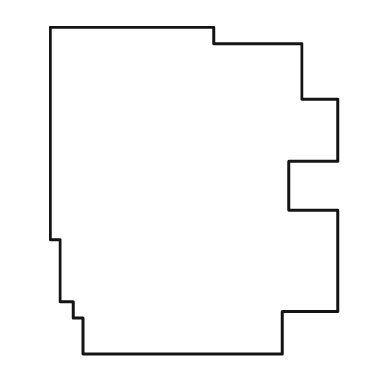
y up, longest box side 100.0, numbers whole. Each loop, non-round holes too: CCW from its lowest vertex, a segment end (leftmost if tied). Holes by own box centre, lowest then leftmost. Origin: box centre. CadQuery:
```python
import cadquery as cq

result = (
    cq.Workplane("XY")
    .moveTo(-34.0, -50.0)
    .lineTo(27.0, -50.0)
    .lineTo(27.0, -37.0)
    .lineTo(44.0, -37.0)
    .lineTo(44.0, -6.0)
    .lineTo(29.0, -6.0)
    .lineTo(29.0, 9.0)
    .lineTo(44.0, 9.0)
    .lineTo(44.0, 28.0)
    .lineTo(33.0, 28.0)
    .lineTo(33.0, 45.0)
    .lineTo(6.0, 45.0)
    .lineTo(6.0, 50.0)
    .lineTo(-44.0, 50.0)
    .lineTo(-44.0, -15.0)
    .lineTo(-41.0, -15.0)
    .lineTo(-41.0, -34.0)
    .lineTo(-37.0, -34.0)
    .lineTo(-37.0, -39.0)
    .lineTo(-34.0, -39.0)
    .close()
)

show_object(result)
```